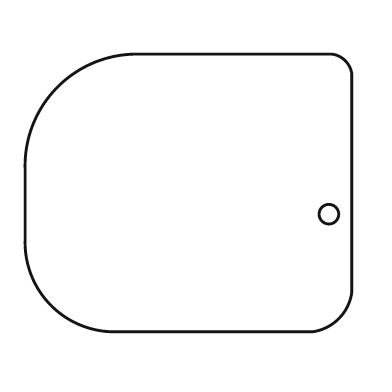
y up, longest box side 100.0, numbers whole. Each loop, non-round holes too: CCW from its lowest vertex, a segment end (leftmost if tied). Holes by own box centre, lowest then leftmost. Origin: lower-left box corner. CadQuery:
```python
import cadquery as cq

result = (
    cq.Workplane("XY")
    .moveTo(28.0, 0.0)
    .lineTo(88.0, 0.0)
    .threePointArc((96.0, 4.0), (100.0, 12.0))
    .lineTo(100.0, 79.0)
    .threePointArc((98.0, 83.0), (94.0, 85.0))
    .lineTo(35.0, 85.0)
    .threePointArc((10.0, 75.0), (0.0, 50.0))
    .lineTo(0.0, 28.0)
    .threePointArc((8.0, 8.0), (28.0, 0.0))
    .close()
    .moveTo(93.0, 36.0)
    .circle(3.0)
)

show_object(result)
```